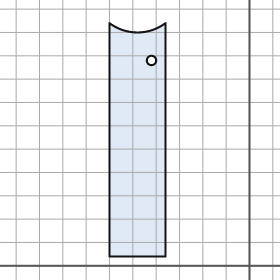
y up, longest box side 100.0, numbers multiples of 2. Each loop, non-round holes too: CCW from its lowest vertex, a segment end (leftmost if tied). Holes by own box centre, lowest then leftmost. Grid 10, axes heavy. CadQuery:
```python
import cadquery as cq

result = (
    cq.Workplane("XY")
    .moveTo(-60.0, 4.0)
    .lineTo(-36.0, 4.0)
    .lineTo(-36.0, 104.0)
    .threePointArc((-48.0, 100.0), (-60.0, 104.0))
    .close()
    .moveTo(-42.0, 88.0)
    .circle(2.0)
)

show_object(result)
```